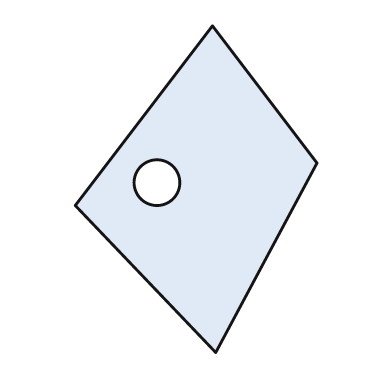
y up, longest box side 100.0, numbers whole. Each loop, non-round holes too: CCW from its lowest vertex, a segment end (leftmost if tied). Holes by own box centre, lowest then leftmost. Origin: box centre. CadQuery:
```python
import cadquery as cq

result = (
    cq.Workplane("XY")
    .moveTo(6.0, -50.0)
    .lineTo(37.0, 8.0)
    .lineTo(5.0, 50.0)
    .lineTo(-37.0, -5.0)
    .close()
    .moveTo(-12.0, 2.0)
    .circle(7.0)
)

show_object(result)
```